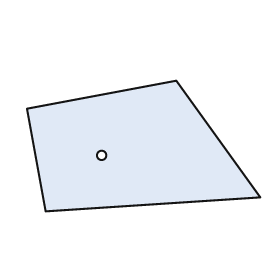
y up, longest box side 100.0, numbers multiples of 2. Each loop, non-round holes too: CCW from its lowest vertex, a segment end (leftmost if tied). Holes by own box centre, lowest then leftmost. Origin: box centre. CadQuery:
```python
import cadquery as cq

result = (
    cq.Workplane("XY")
    .moveTo(-42.0, -28.0)
    .lineTo(50.0, -22.0)
    .lineTo(14.0, 28.0)
    .lineTo(-50.0, 16.0)
    .close()
    .moveTo(-18.0, -4.0)
    .circle(2.0)
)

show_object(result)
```